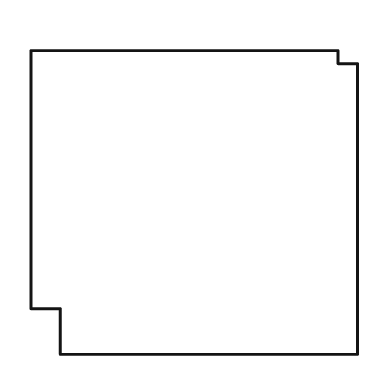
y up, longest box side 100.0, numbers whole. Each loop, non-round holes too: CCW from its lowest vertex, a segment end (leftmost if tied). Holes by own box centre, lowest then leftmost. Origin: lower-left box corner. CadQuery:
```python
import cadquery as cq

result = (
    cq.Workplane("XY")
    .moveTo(9.0, 0.0)
    .lineTo(100.0, 0.0)
    .lineTo(100.0, 89.0)
    .lineTo(94.0, 89.0)
    .lineTo(94.0, 93.0)
    .lineTo(0.0, 93.0)
    .lineTo(0.0, 14.0)
    .lineTo(9.0, 14.0)
    .close()
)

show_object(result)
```